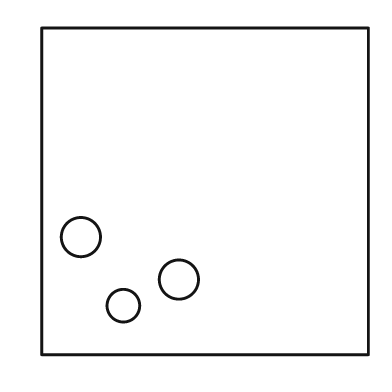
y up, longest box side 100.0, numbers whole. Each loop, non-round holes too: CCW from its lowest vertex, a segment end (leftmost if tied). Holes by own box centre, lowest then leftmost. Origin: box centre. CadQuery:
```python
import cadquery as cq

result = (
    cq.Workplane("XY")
    .moveTo(-50.0, -50.0)
    .lineTo(50.0, -50.0)
    .lineTo(50.0, 50.0)
    .lineTo(-50.0, 50.0)
    .close()
    .moveTo(-25.0, -35.0)
    .circle(5.0)
    .moveTo(-8.0, -27.0)
    .circle(6.0)
    .moveTo(-38.0, -14.0)
    .circle(6.0)
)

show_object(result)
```